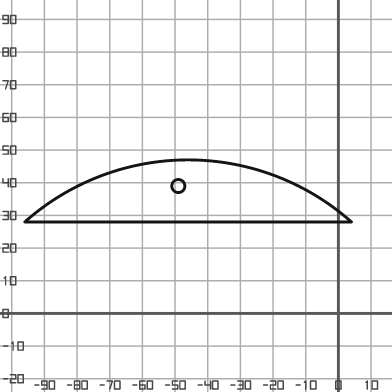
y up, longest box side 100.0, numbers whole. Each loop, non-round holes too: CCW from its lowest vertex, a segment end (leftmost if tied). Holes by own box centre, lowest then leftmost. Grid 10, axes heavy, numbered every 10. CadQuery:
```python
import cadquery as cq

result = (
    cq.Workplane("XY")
    .moveTo(-96.0, 28.0)
    .lineTo(4.0, 28.0)
    .threePointArc((-46.0, 47.0), (-96.0, 28.0))
    .close()
    .moveTo(-49.0, 39.0)
    .circle(2.0)
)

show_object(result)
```